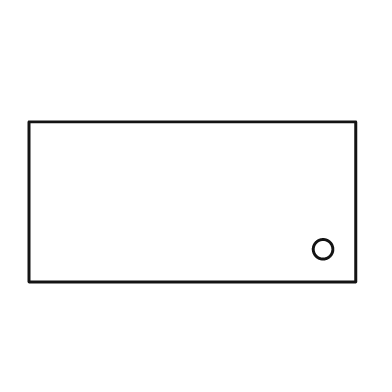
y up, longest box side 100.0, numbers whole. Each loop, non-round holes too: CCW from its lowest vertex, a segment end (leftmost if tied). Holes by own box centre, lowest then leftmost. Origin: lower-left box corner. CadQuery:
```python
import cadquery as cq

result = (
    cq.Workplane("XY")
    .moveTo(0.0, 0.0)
    .lineTo(100.0, 0.0)
    .lineTo(100.0, 49.0)
    .lineTo(0.0, 49.0)
    .close()
    .moveTo(90.0, 10.0)
    .circle(3.0)
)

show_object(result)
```